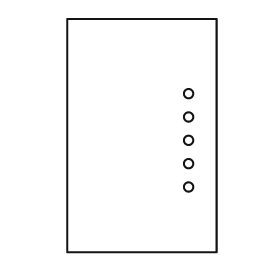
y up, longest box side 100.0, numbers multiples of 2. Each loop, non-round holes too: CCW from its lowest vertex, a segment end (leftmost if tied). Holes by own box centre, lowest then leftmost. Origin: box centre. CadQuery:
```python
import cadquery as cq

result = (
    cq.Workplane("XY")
    .moveTo(-32.0, -50.0)
    .lineTo(32.0, -50.0)
    .lineTo(32.0, 50.0)
    .lineTo(-32.0, 50.0)
    .close()
    .moveTo(20.0, -22.0)
    .circle(2.0)
    .moveTo(20.0, -12.0)
    .circle(2.0)
    .moveTo(20.0, -2.0)
    .circle(2.0)
    .moveTo(20.0, 8.0)
    .circle(2.0)
    .moveTo(20.0, 18.0)
    .circle(2.0)
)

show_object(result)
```